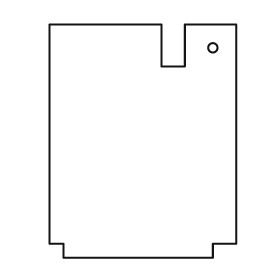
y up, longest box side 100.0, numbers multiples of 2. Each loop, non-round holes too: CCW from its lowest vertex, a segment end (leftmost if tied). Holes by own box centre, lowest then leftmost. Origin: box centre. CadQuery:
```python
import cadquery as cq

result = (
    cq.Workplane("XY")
    .moveTo(-34.0, -50.0)
    .lineTo(30.0, -50.0)
    .lineTo(30.0, -44.0)
    .lineTo(40.0, -44.0)
    .lineTo(40.0, 50.0)
    .lineTo(18.0, 50.0)
    .lineTo(18.0, 32.0)
    .lineTo(8.0, 32.0)
    .lineTo(8.0, 50.0)
    .lineTo(-40.0, 50.0)
    .lineTo(-40.0, -44.0)
    .lineTo(-34.0, -44.0)
    .close()
    .moveTo(30.0, 40.0)
    .circle(2.0)
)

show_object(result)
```